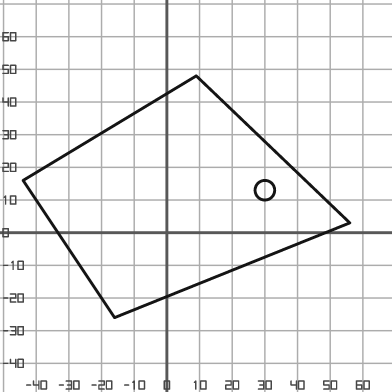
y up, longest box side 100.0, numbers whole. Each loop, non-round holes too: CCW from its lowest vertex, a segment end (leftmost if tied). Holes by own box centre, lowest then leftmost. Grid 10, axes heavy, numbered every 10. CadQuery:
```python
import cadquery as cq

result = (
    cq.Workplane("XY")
    .moveTo(-16.0, -26.0)
    .lineTo(56.0, 3.0)
    .lineTo(9.0, 48.0)
    .lineTo(-44.0, 16.0)
    .close()
    .moveTo(30.0, 13.0)
    .circle(3.0)
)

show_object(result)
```